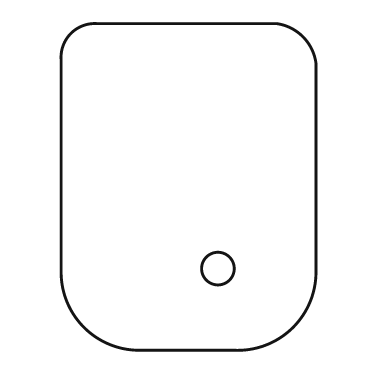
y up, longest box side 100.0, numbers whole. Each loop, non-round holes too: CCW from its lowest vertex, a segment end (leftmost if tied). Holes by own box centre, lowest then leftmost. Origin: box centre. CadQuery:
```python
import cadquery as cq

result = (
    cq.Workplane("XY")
    .moveTo(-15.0, -50.0)
    .lineTo(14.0, -50.0)
    .threePointArc((32.0, -43.0), (39.0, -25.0))
    .lineTo(39.0, 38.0)
    .threePointArc((35.0, 46.0), (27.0, 50.0))
    .lineTo(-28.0, 50.0)
    .threePointArc((-36.0, 47.0), (-39.0, 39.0))
    .lineTo(-39.0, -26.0)
    .threePointArc((-32.0, -43.0), (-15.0, -50.0))
    .close()
    .moveTo(9.0, -25.0)
    .circle(5.0)
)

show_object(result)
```